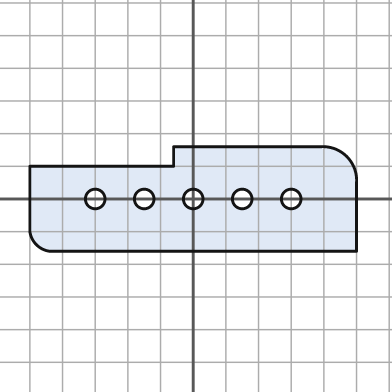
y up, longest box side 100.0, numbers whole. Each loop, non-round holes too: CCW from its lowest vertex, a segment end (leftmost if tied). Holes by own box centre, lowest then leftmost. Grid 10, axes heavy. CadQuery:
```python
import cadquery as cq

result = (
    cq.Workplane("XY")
    .moveTo(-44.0, -16.0)
    .lineTo(50.0, -16.0)
    .lineTo(50.0, 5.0)
    .threePointArc((47.0, 13.0), (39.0, 16.0))
    .lineTo(-6.0, 16.0)
    .lineTo(-6.0, 10.0)
    .lineTo(-50.0, 10.0)
    .lineTo(-50.0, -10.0)
    .threePointArc((-48.0, -14.0), (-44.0, -16.0))
    .close()
    .moveTo(-30.0, 0.0)
    .circle(3.0)
    .moveTo(-15.0, 0.0)
    .circle(3.0)
    .moveTo(0.0, 0.0)
    .circle(3.0)
    .moveTo(15.0, 0.0)
    .circle(3.0)
    .moveTo(30.0, 0.0)
    .circle(3.0)
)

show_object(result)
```